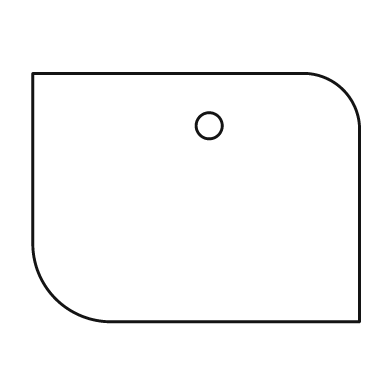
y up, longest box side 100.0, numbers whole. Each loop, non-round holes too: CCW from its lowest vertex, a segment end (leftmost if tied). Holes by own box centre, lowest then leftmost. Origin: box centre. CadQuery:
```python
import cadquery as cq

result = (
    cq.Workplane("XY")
    .moveTo(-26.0, -38.0)
    .lineTo(50.0, -38.0)
    .lineTo(50.0, 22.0)
    .threePointArc((45.0, 33.0), (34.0, 38.0))
    .lineTo(-50.0, 38.0)
    .lineTo(-50.0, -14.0)
    .threePointArc((-43.0, -31.0), (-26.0, -38.0))
    .close()
    .moveTo(4.0, 22.0)
    .circle(4.0)
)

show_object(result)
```